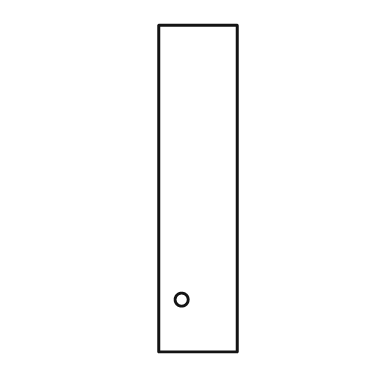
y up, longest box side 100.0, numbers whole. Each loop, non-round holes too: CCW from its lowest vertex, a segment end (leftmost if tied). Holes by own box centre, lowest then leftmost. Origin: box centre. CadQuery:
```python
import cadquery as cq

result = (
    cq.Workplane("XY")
    .moveTo(-12.0, -50.0)
    .lineTo(12.0, -50.0)
    .lineTo(12.0, 50.0)
    .lineTo(-12.0, 50.0)
    .close()
    .moveTo(-5.0, -34.0)
    .circle(2.0)
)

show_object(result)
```